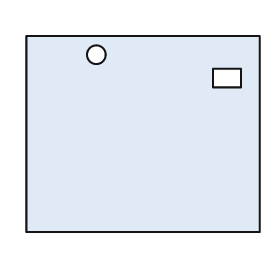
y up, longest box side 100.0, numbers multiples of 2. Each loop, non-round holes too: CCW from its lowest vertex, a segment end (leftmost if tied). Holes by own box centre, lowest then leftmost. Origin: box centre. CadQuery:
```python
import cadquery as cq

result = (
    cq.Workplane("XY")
    .moveTo(-50.0, -42.0)
    .lineTo(50.0, -42.0)
    .lineTo(50.0, 42.0)
    .lineTo(-50.0, 42.0)
    .close()
    .moveTo(30.0, 20.0)
    .lineTo(42.0, 20.0)
    .lineTo(42.0, 28.0)
    .lineTo(30.0, 28.0)
    .close()
    .moveTo(-20.0, 34.0)
    .circle(4.0)
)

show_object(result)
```